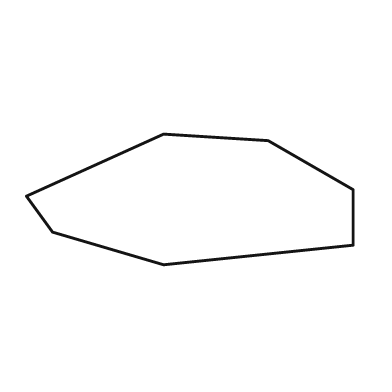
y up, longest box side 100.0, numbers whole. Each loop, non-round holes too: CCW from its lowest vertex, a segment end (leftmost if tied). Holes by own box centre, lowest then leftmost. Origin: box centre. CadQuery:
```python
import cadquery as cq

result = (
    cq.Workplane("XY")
    .moveTo(-8.0, -20.0)
    .lineTo(50.0, -14.0)
    .lineTo(50.0, 3.0)
    .lineTo(24.0, 18.0)
    .lineTo(-8.0, 20.0)
    .lineTo(-50.0, 1.0)
    .lineTo(-42.0, -10.0)
    .close()
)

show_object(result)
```